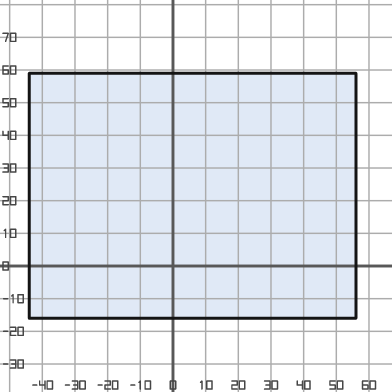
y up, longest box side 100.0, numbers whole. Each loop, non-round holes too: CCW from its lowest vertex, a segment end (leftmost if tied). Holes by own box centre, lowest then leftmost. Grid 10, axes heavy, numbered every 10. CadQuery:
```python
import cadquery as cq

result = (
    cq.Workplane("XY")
    .moveTo(-44.0, -16.0)
    .lineTo(56.0, -16.0)
    .lineTo(56.0, 59.0)
    .lineTo(-44.0, 59.0)
    .close()
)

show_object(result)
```